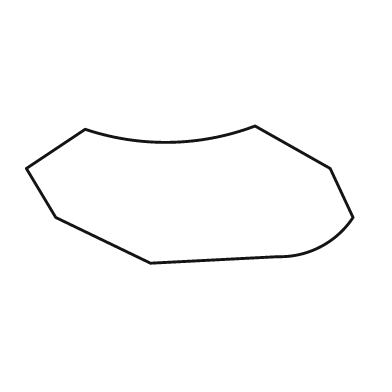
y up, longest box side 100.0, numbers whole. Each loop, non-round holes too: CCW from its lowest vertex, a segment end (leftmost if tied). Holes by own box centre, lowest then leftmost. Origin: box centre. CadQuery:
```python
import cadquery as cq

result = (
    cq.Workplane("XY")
    .moveTo(-12.0, -21.0)
    .lineTo(27.0, -19.0)
    .threePointArc((40.0, -16.0), (50.0, -7.0))
    .lineTo(43.0, 8.0)
    .lineTo(20.0, 21.0)
    .threePointArc((-6.0, 16.0), (-32.0, 20.0))
    .lineTo(-50.0, 8.0)
    .lineTo(-41.0, -7.0)
    .close()
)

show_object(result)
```